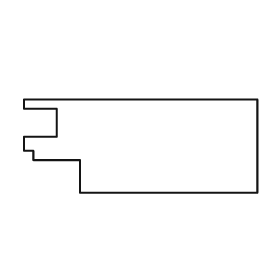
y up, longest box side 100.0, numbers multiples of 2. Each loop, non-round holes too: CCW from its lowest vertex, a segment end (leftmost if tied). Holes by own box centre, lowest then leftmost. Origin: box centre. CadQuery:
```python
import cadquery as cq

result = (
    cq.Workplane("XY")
    .moveTo(-26.0, -20.0)
    .lineTo(50.0, -20.0)
    .lineTo(50.0, 20.0)
    .lineTo(-50.0, 20.0)
    .lineTo(-50.0, 16.0)
    .lineTo(-36.0, 16.0)
    .lineTo(-36.0, 4.0)
    .lineTo(-50.0, 4.0)
    .lineTo(-50.0, -2.0)
    .lineTo(-46.0, -2.0)
    .lineTo(-46.0, -6.0)
    .lineTo(-26.0, -6.0)
    .close()
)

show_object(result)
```